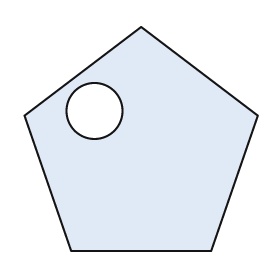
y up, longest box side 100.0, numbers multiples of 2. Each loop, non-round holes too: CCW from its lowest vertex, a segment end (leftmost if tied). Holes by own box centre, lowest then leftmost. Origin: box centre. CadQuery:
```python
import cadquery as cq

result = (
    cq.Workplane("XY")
    .moveTo(-30.0, -48.0)
    .lineTo(30.0, -48.0)
    .lineTo(50.0, 10.0)
    .lineTo(0.0, 48.0)
    .lineTo(-50.0, 10.0)
    .close()
    .moveTo(-20.0, 12.0)
    .circle(12.0)
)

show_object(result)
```